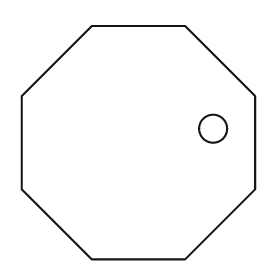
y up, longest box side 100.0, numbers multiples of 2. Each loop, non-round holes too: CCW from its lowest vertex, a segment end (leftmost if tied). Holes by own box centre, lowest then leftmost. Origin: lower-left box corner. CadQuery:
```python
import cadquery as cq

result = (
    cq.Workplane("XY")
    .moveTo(30.0, 0.0)
    .lineTo(70.0, 0.0)
    .lineTo(100.0, 30.0)
    .lineTo(100.0, 70.0)
    .lineTo(70.0, 100.0)
    .lineTo(30.0, 100.0)
    .lineTo(0.0, 70.0)
    .lineTo(0.0, 30.0)
    .close()
    .moveTo(82.0, 56.0)
    .circle(6.0)
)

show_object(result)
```